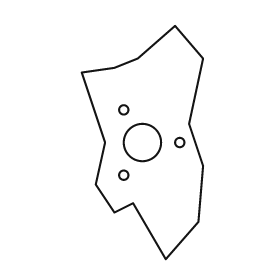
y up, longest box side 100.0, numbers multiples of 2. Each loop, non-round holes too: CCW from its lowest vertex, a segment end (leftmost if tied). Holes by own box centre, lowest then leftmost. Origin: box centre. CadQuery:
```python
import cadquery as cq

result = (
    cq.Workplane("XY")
    .moveTo(10.0, -50.0)
    .lineTo(24.0, -34.0)
    .lineTo(26.0, -10.0)
    .lineTo(20.0, 8.0)
    .lineTo(26.0, 36.0)
    .lineTo(14.0, 50.0)
    .lineTo(-2.0, 36.0)
    .lineTo(-12.0, 32.0)
    .lineTo(-26.0, 30.0)
    .lineTo(-16.0, 0.0)
    .lineTo(-20.0, -18.0)
    .lineTo(-12.0, -30.0)
    .lineTo(-4.0, -26.0)
    .close()
    .moveTo(-8.0, -14.0)
    .circle(2.0)
    .moveTo(0.0, 0.0)
    .circle(8.0)
    .moveTo(16.0, 0.0)
    .circle(2.0)
    .moveTo(-8.0, 14.0)
    .circle(2.0)
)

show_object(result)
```